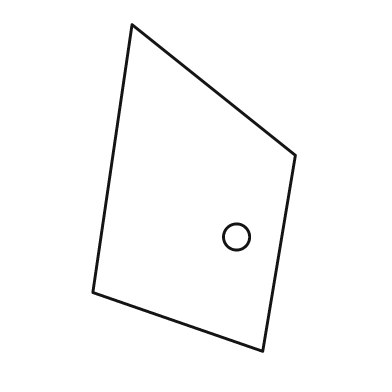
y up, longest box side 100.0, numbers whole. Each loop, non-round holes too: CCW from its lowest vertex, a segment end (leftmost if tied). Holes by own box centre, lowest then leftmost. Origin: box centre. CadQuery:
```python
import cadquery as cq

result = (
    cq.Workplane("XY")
    .moveTo(21.0, -50.0)
    .lineTo(31.0, 10.0)
    .lineTo(-19.0, 50.0)
    .lineTo(-31.0, -32.0)
    .close()
    .moveTo(13.0, -15.0)
    .circle(4.0)
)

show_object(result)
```